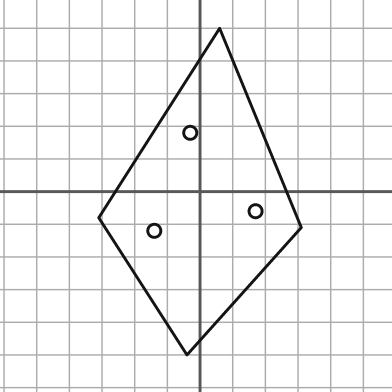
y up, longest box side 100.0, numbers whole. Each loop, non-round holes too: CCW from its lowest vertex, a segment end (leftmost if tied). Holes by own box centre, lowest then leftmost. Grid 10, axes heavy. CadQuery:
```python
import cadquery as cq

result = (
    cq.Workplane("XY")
    .moveTo(-4.0, -50.0)
    .lineTo(31.0, -11.0)
    .lineTo(6.0, 50.0)
    .lineTo(-31.0, -8.0)
    .close()
    .moveTo(-14.0, -12.0)
    .circle(2.0)
    .moveTo(17.0, -6.0)
    .circle(2.0)
    .moveTo(-3.0, 18.0)
    .circle(2.0)
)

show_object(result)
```